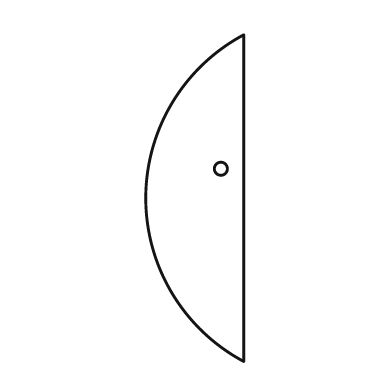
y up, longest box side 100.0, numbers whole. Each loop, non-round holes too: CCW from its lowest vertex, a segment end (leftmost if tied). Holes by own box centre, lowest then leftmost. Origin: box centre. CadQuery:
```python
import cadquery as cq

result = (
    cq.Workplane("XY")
    .moveTo(15.0, -50.0)
    .lineTo(15.0, 50.0)
    .threePointArc((-15.0, 0.0), (15.0, -50.0))
    .close()
    .moveTo(8.0, 9.0)
    .circle(2.0)
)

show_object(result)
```